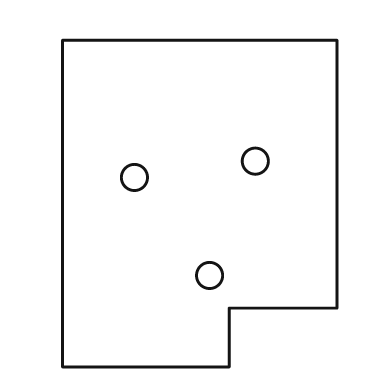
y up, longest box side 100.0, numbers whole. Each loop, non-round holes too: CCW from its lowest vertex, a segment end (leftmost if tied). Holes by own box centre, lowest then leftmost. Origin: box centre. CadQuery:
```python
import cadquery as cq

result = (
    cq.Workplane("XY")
    .moveTo(-42.0, -50.0)
    .lineTo(9.0, -50.0)
    .lineTo(9.0, -32.0)
    .lineTo(42.0, -32.0)
    .lineTo(42.0, 50.0)
    .lineTo(-42.0, 50.0)
    .close()
    .moveTo(3.0, -22.0)
    .circle(4.0)
    .moveTo(-20.0, 8.0)
    .circle(4.0)
    .moveTo(17.0, 13.0)
    .circle(4.0)
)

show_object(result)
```